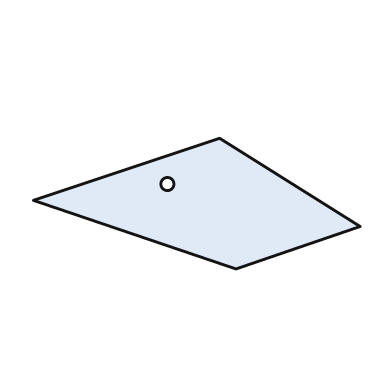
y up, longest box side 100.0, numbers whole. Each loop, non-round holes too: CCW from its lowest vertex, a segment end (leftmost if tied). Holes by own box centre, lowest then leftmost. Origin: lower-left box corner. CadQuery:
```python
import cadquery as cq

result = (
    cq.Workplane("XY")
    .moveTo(62.0, 0.0)
    .lineTo(100.0, 13.0)
    .lineTo(57.0, 40.0)
    .lineTo(0.0, 21.0)
    .close()
    .moveTo(41.0, 26.0)
    .circle(2.0)
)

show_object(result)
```